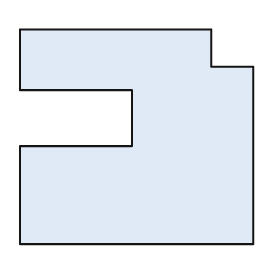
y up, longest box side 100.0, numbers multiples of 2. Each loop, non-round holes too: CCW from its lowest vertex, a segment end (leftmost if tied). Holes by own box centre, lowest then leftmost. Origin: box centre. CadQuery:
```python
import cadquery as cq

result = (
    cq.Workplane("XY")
    .moveTo(-50.0, -46.0)
    .lineTo(50.0, -46.0)
    .lineTo(50.0, 30.0)
    .lineTo(32.0, 30.0)
    .lineTo(32.0, 46.0)
    .lineTo(-50.0, 46.0)
    .lineTo(-50.0, 20.0)
    .lineTo(-2.0, 20.0)
    .lineTo(-2.0, -4.0)
    .lineTo(-50.0, -4.0)
    .close()
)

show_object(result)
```